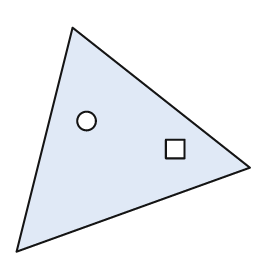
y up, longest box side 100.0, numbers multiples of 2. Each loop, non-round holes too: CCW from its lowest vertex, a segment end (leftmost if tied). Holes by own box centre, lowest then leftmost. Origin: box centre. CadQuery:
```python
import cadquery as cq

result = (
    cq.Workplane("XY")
    .moveTo(-50.0, -48.0)
    .lineTo(50.0, -12.0)
    .lineTo(-26.0, 48.0)
    .close()
    .moveTo(14.0, -8.0)
    .lineTo(22.0, -8.0)
    .lineTo(22.0, 0.0)
    .lineTo(14.0, 0.0)
    .close()
    .moveTo(-20.0, 8.0)
    .circle(4.0)
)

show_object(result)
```